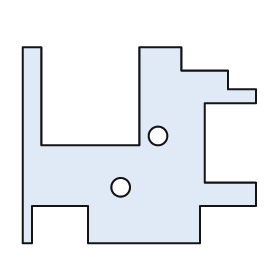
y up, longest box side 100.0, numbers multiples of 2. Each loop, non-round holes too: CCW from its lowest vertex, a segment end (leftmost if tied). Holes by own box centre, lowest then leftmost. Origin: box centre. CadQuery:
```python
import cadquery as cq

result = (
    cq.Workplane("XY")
    .moveTo(-50.0, -42.0)
    .lineTo(-46.0, -42.0)
    .lineTo(-46.0, -26.0)
    .lineTo(-22.0, -26.0)
    .lineTo(-22.0, -42.0)
    .lineTo(26.0, -42.0)
    .lineTo(26.0, -26.0)
    .lineTo(50.0, -26.0)
    .lineTo(50.0, -16.0)
    .lineTo(28.0, -16.0)
    .lineTo(28.0, 18.0)
    .lineTo(50.0, 18.0)
    .lineTo(50.0, 24.0)
    .lineTo(38.0, 24.0)
    .lineTo(38.0, 32.0)
    .lineTo(18.0, 32.0)
    .lineTo(18.0, 42.0)
    .lineTo(0.0, 42.0)
    .lineTo(0.0, 0.0)
    .lineTo(-42.0, 0.0)
    .lineTo(-42.0, 42.0)
    .lineTo(-50.0, 42.0)
    .close()
    .moveTo(-8.0, -18.0)
    .circle(4.0)
    .moveTo(8.0, 4.0)
    .circle(4.0)
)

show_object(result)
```